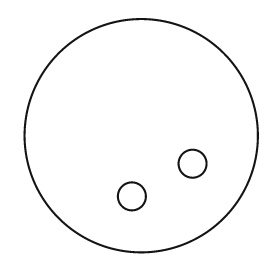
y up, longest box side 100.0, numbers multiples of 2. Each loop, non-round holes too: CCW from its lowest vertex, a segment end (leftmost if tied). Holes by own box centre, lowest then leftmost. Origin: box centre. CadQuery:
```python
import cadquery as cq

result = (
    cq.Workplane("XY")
    .moveTo(0.0, 0.0)
    .circle(50.0)
    .moveTo(-4.0, -26.0)
    .circle(6.0)
    .moveTo(22.0, -12.0)
    .circle(6.0)
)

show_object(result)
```